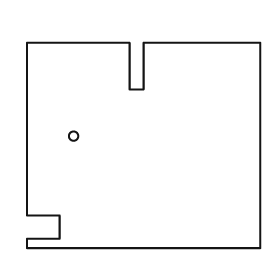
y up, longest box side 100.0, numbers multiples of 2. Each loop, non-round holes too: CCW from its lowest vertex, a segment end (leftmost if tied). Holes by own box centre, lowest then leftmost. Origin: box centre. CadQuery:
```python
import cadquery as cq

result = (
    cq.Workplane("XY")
    .moveTo(-50.0, -44.0)
    .lineTo(50.0, -44.0)
    .lineTo(50.0, 44.0)
    .lineTo(0.0, 44.0)
    .lineTo(0.0, 24.0)
    .lineTo(-6.0, 24.0)
    .lineTo(-6.0, 44.0)
    .lineTo(-50.0, 44.0)
    .lineTo(-50.0, -30.0)
    .lineTo(-36.0, -30.0)
    .lineTo(-36.0, -40.0)
    .lineTo(-50.0, -40.0)
    .close()
    .moveTo(-30.0, 4.0)
    .circle(2.0)
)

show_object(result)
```